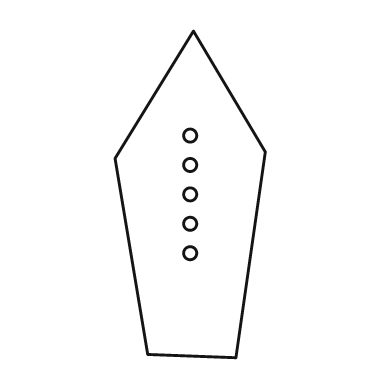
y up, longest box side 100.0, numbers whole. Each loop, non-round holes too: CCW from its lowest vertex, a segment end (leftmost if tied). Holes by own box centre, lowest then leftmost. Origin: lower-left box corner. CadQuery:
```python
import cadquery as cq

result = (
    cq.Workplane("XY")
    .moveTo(37.0, 0.0)
    .lineTo(46.0, 63.0)
    .lineTo(24.0, 100.0)
    .lineTo(0.0, 61.0)
    .lineTo(10.0, 1.0)
    .close()
    .moveTo(23.0, 32.0)
    .circle(2.0)
    .moveTo(23.0, 41.0)
    .circle(2.0)
    .moveTo(23.0, 50.0)
    .circle(2.0)
    .moveTo(23.0, 59.0)
    .circle(2.0)
    .moveTo(23.0, 68.0)
    .circle(2.0)
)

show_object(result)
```